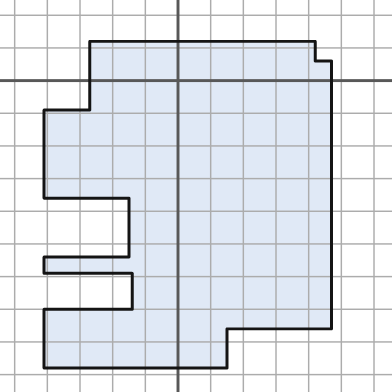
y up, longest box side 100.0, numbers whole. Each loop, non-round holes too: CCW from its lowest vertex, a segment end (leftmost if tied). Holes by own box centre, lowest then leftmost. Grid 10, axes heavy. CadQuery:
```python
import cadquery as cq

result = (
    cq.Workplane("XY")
    .moveTo(-41.0, -88.0)
    .lineTo(15.0, -88.0)
    .lineTo(15.0, -76.0)
    .lineTo(47.0, -76.0)
    .lineTo(47.0, 6.0)
    .lineTo(42.0, 6.0)
    .lineTo(42.0, 12.0)
    .lineTo(-27.0, 12.0)
    .lineTo(-27.0, -9.0)
    .lineTo(-41.0, -9.0)
    .lineTo(-41.0, -36.0)
    .lineTo(-15.0, -36.0)
    .lineTo(-15.0, -54.0)
    .lineTo(-41.0, -54.0)
    .lineTo(-41.0, -59.0)
    .lineTo(-14.0, -59.0)
    .lineTo(-14.0, -70.0)
    .lineTo(-41.0, -70.0)
    .close()
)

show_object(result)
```